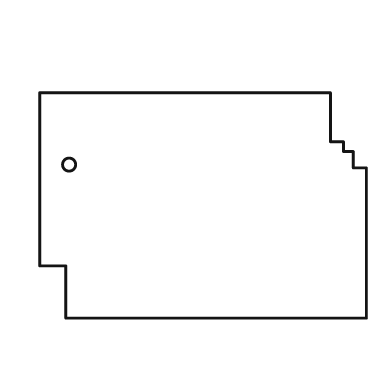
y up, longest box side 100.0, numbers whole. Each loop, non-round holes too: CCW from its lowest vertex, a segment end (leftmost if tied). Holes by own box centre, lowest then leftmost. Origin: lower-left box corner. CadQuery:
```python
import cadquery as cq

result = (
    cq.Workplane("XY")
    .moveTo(8.0, 0.0)
    .lineTo(100.0, 0.0)
    .lineTo(100.0, 46.0)
    .lineTo(96.0, 46.0)
    .lineTo(96.0, 51.0)
    .lineTo(93.0, 51.0)
    .lineTo(93.0, 54.0)
    .lineTo(89.0, 54.0)
    .lineTo(89.0, 69.0)
    .lineTo(0.0, 69.0)
    .lineTo(0.0, 16.0)
    .lineTo(8.0, 16.0)
    .close()
    .moveTo(9.0, 47.0)
    .circle(2.0)
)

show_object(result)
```